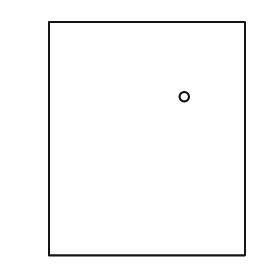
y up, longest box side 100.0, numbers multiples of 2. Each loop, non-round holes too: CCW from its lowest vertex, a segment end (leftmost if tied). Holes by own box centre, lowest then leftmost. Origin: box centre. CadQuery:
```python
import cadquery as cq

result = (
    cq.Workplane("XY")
    .moveTo(-42.0, -50.0)
    .lineTo(42.0, -50.0)
    .lineTo(42.0, 50.0)
    .lineTo(-42.0, 50.0)
    .close()
    .moveTo(16.0, 18.0)
    .circle(2.0)
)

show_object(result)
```